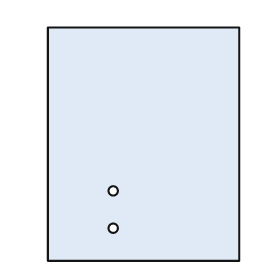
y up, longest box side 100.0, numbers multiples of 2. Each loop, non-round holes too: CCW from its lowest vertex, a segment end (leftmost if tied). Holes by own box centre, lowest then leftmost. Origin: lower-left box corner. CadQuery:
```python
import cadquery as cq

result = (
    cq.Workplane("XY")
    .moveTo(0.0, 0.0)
    .lineTo(82.0, 0.0)
    .lineTo(82.0, 100.0)
    .lineTo(0.0, 100.0)
    .close()
    .moveTo(28.0, 14.0)
    .circle(2.0)
    .moveTo(28.0, 30.0)
    .circle(2.0)
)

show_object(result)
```